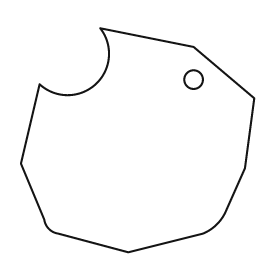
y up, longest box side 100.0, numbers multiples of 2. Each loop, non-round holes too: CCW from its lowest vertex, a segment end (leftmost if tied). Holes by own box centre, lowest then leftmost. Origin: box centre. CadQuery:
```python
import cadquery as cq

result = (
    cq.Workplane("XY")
    .moveTo(-4.0, -48.0)
    .lineTo(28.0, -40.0)
    .threePointArc((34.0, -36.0), (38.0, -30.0))
    .lineTo(46.0, -12.0)
    .lineTo(50.0, 18.0)
    .lineTo(24.0, 40.0)
    .lineTo(-16.0, 48.0)
    .threePointArc((-18.0, 24.0), (-42.0, 24.0))
    .lineTo(-50.0, -10.0)
    .lineTo(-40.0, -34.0)
    .threePointArc((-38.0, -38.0), (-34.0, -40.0))
    .close()
    .moveTo(24.0, 26.0)
    .circle(4.0)
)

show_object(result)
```